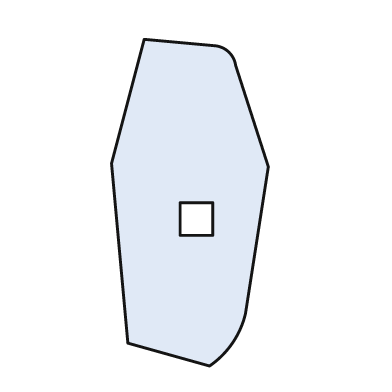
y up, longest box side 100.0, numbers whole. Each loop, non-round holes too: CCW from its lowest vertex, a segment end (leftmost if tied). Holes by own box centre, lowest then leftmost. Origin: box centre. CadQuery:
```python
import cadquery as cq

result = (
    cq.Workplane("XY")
    .moveTo(6.0, -50.0)
    .threePointArc((13.0, -43.0), (17.0, -34.0))
    .lineTo(24.0, 11.0)
    .lineTo(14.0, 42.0)
    .threePointArc((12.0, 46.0), (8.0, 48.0))
    .lineTo(-14.0, 50.0)
    .lineTo(-24.0, 12.0)
    .lineTo(-19.0, -43.0)
    .close()
    .moveTo(-3.0, -10.0)
    .lineTo(7.0, -10.0)
    .lineTo(7.0, 0.0)
    .lineTo(-3.0, 0.0)
    .close()
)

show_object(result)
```